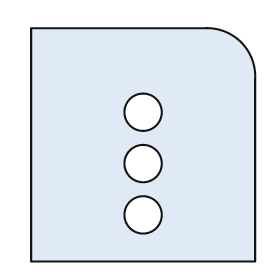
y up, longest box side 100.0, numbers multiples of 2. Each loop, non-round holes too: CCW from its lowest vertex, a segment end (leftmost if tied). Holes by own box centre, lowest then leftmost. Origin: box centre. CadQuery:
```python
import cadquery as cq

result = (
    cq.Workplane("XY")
    .moveTo(-48.0, -50.0)
    .lineTo(48.0, -50.0)
    .lineTo(48.0, 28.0)
    .threePointArc((42.0, 44.0), (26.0, 50.0))
    .lineTo(-48.0, 50.0)
    .close()
    .moveTo(0.0, -30.0)
    .circle(8.0)
    .moveTo(0.0, -8.0)
    .circle(8.0)
    .moveTo(0.0, 14.0)
    .circle(8.0)
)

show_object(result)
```